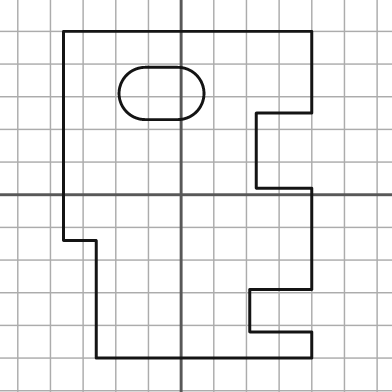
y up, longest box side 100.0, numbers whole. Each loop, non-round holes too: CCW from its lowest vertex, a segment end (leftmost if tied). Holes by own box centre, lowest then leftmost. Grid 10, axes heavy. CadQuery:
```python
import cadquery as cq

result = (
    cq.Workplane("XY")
    .moveTo(-26.0, -50.0)
    .lineTo(40.0, -50.0)
    .lineTo(40.0, -42.0)
    .lineTo(21.0, -42.0)
    .lineTo(21.0, -29.0)
    .lineTo(40.0, -29.0)
    .lineTo(40.0, 2.0)
    .lineTo(23.0, 2.0)
    .lineTo(23.0, 25.0)
    .lineTo(40.0, 25.0)
    .lineTo(40.0, 50.0)
    .lineTo(-36.0, 50.0)
    .lineTo(-36.0, -14.0)
    .lineTo(-26.0, -14.0)
    .close()
    .moveTo(-11.0, 23.0)
    .lineTo(-1.0, 23.0)
    .threePointArc((7.0, 31.0), (-1.0, 39.0))
    .lineTo(-11.0, 39.0)
    .threePointArc((-19.0, 31.0), (-11.0, 23.0))
    .close()
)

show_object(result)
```